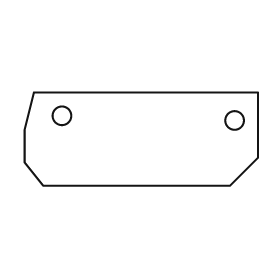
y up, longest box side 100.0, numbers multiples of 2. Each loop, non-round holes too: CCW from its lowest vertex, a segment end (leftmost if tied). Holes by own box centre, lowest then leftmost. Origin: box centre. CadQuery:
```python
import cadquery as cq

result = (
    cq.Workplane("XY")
    .moveTo(-42.0, -20.0)
    .lineTo(38.0, -20.0)
    .lineTo(50.0, -8.0)
    .lineTo(50.0, 20.0)
    .lineTo(-46.0, 20.0)
    .lineTo(-50.0, 4.0)
    .lineTo(-50.0, -10.0)
    .close()
    .moveTo(40.0, 8.0)
    .circle(4.0)
    .moveTo(-34.0, 10.0)
    .circle(4.0)
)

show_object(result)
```